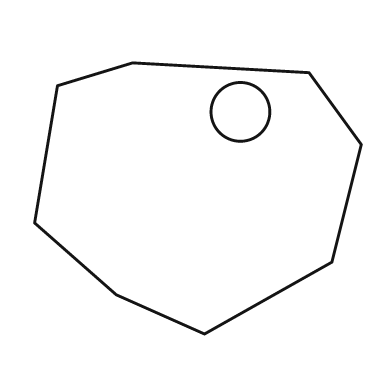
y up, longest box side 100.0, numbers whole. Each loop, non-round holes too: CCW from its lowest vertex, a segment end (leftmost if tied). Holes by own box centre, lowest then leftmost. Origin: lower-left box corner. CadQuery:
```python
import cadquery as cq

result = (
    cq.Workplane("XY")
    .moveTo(52.0, 0.0)
    .lineTo(91.0, 22.0)
    .lineTo(100.0, 58.0)
    .lineTo(84.0, 80.0)
    .lineTo(30.0, 83.0)
    .lineTo(7.0, 76.0)
    .lineTo(0.0, 34.0)
    .lineTo(25.0, 12.0)
    .close()
    .moveTo(63.0, 68.0)
    .circle(9.0)
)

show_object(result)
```